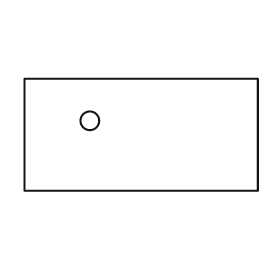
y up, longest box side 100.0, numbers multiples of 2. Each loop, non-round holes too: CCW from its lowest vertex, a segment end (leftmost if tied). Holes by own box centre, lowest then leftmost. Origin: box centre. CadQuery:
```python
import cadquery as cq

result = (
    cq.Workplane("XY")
    .moveTo(-50.0, -24.0)
    .lineTo(50.0, -24.0)
    .lineTo(50.0, 24.0)
    .lineTo(-50.0, 24.0)
    .close()
    .moveTo(-22.0, 6.0)
    .circle(4.0)
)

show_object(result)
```